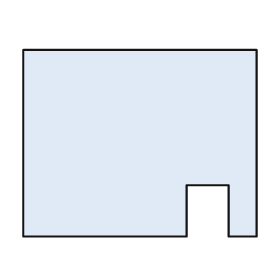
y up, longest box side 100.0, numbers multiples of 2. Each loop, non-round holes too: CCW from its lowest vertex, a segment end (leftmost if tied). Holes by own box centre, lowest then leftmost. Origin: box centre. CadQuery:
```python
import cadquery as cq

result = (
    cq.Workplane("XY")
    .moveTo(-50.0, -40.0)
    .lineTo(20.0, -40.0)
    .lineTo(20.0, -18.0)
    .lineTo(38.0, -18.0)
    .lineTo(38.0, -40.0)
    .lineTo(50.0, -40.0)
    .lineTo(50.0, 40.0)
    .lineTo(-50.0, 40.0)
    .close()
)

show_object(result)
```